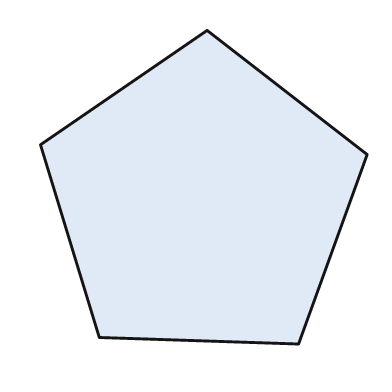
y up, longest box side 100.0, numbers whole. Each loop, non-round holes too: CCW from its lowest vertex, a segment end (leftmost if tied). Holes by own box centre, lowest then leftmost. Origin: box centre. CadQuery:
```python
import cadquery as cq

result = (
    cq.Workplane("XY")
    .moveTo(29.0, -48.0)
    .lineTo(50.0, 10.0)
    .lineTo(1.0, 48.0)
    .lineTo(-50.0, 13.0)
    .lineTo(-32.0, -46.0)
    .close()
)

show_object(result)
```